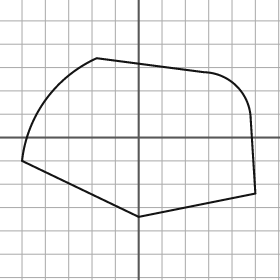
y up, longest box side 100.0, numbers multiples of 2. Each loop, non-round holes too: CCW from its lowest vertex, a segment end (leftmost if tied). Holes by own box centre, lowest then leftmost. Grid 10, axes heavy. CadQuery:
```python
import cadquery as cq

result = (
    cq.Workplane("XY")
    .moveTo(0.0, -34.0)
    .lineTo(50.0, -24.0)
    .lineTo(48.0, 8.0)
    .threePointArc((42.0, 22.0), (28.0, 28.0))
    .lineTo(-18.0, 34.0)
    .threePointArc((-40.0, 16.0), (-50.0, -10.0))
    .close()
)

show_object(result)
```